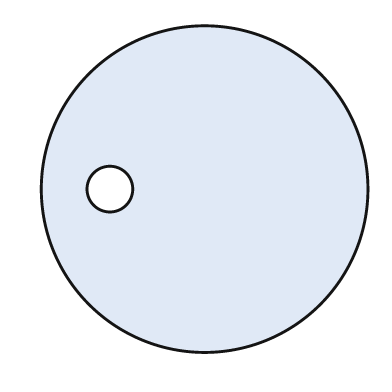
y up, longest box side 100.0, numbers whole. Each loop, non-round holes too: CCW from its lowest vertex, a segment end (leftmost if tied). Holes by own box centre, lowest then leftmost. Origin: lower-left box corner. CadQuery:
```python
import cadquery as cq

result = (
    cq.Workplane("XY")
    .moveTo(50.0, 50.0)
    .circle(50.0)
    .moveTo(21.0, 50.0)
    .circle(7.0)
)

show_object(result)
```